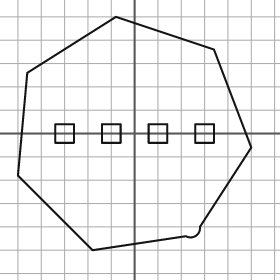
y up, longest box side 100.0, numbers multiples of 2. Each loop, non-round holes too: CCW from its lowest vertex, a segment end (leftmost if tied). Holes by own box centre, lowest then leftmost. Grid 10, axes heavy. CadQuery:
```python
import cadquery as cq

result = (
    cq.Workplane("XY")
    .moveTo(-18.0, -50.0)
    .lineTo(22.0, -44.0)
    .threePointArc((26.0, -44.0), (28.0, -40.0))
    .lineTo(50.0, -6.0)
    .lineTo(34.0, 36.0)
    .lineTo(-8.0, 50.0)
    .lineTo(-46.0, 26.0)
    .lineTo(-50.0, -18.0)
    .close()
    .moveTo(-34.0, -4.0)
    .lineTo(-26.0, -4.0)
    .lineTo(-26.0, 4.0)
    .lineTo(-34.0, 4.0)
    .close()
    .moveTo(-14.0, -4.0)
    .lineTo(-6.0, -4.0)
    .lineTo(-6.0, 4.0)
    .lineTo(-14.0, 4.0)
    .close()
    .moveTo(6.0, -4.0)
    .lineTo(14.0, -4.0)
    .lineTo(14.0, 4.0)
    .lineTo(6.0, 4.0)
    .close()
    .moveTo(26.0, -4.0)
    .lineTo(34.0, -4.0)
    .lineTo(34.0, 4.0)
    .lineTo(26.0, 4.0)
    .close()
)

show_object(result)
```